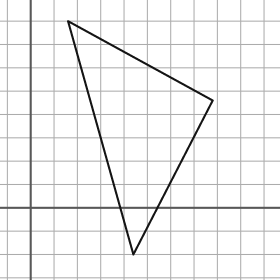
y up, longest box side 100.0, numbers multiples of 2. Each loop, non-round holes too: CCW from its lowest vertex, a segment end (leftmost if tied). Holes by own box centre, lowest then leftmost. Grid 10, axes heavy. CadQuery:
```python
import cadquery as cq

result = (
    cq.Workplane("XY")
    .moveTo(44.0, -20.0)
    .lineTo(78.0, 46.0)
    .lineTo(16.0, 80.0)
    .close()
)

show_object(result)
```